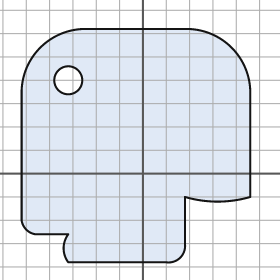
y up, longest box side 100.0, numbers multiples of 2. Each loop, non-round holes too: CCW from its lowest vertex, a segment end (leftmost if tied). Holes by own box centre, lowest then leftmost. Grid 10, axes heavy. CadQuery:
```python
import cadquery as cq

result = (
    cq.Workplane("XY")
    .moveTo(-32.0, -38.0)
    .lineTo(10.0, -38.0)
    .threePointArc((16.0, -36.0), (18.0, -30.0))
    .lineTo(18.0, -10.0)
    .threePointArc((32.0, -12.0), (46.0, -10.0))
    .lineTo(46.0, 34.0)
    .threePointArc((38.0, 54.0), (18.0, 62.0))
    .lineTo(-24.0, 62.0)
    .threePointArc((-44.0, 54.0), (-52.0, 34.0))
    .lineTo(-52.0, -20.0)
    .threePointArc((-50.0, -24.0), (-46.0, -26.0))
    .lineTo(-32.0, -26.0)
    .threePointArc((-34.0, -32.0), (-32.0, -38.0))
    .close()
    .moveTo(-32.0, 40.0)
    .circle(6.0)
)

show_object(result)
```